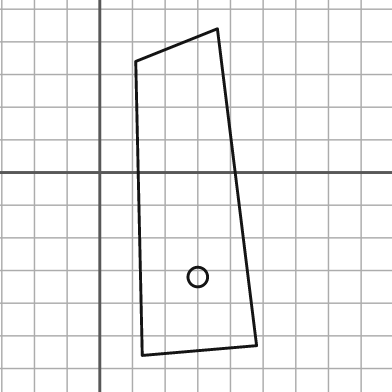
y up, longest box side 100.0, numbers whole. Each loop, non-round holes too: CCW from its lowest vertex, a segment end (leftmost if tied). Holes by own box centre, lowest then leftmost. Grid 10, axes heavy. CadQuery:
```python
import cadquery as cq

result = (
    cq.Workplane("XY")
    .moveTo(13.0, -56.0)
    .lineTo(48.0, -53.0)
    .lineTo(36.0, 44.0)
    .lineTo(11.0, 34.0)
    .close()
    .moveTo(30.0, -32.0)
    .circle(3.0)
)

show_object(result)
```